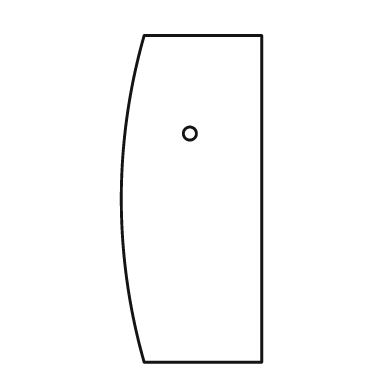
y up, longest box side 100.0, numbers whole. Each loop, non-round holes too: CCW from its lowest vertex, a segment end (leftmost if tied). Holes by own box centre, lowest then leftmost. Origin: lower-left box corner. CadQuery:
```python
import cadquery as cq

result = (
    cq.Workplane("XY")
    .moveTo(7.0, 0.0)
    .lineTo(43.0, 0.0)
    .lineTo(43.0, 100.0)
    .lineTo(7.0, 100.0)
    .threePointArc((0.0, 50.0), (7.0, 0.0))
    .close()
    .moveTo(21.0, 70.0)
    .circle(2.0)
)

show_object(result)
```